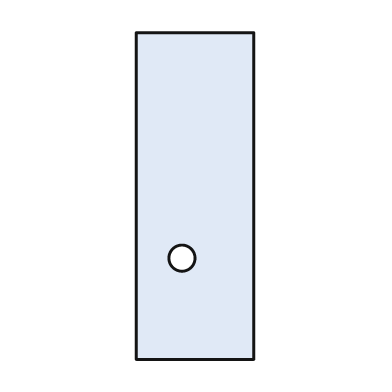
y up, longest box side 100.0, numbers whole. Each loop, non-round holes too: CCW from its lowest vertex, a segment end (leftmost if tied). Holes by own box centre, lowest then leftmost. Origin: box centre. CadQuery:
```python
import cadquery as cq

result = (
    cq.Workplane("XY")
    .moveTo(-18.0, -50.0)
    .lineTo(18.0, -50.0)
    .lineTo(18.0, 50.0)
    .lineTo(-18.0, 50.0)
    .close()
    .moveTo(-4.0, -19.0)
    .circle(4.0)
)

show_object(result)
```